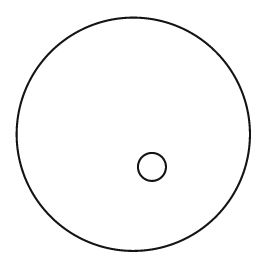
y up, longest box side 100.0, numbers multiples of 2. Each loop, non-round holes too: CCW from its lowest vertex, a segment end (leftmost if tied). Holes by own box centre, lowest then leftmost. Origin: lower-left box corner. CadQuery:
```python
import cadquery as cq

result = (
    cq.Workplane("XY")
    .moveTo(50.0, 50.0)
    .circle(50.0)
    .moveTo(58.0, 36.0)
    .circle(6.0)
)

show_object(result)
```